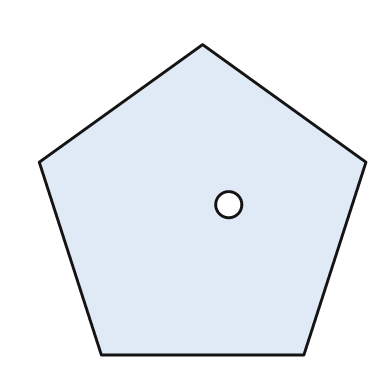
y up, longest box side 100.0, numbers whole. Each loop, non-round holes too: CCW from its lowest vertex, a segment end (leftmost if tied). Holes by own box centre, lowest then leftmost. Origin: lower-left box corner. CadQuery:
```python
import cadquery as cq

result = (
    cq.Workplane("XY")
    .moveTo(19.0, 0.0)
    .lineTo(81.0, 0.0)
    .lineTo(100.0, 59.0)
    .lineTo(50.0, 95.0)
    .lineTo(0.0, 59.0)
    .close()
    .moveTo(58.0, 46.0)
    .circle(4.0)
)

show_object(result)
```